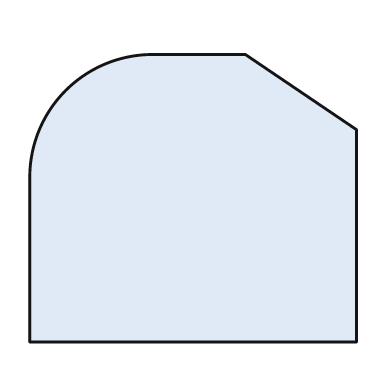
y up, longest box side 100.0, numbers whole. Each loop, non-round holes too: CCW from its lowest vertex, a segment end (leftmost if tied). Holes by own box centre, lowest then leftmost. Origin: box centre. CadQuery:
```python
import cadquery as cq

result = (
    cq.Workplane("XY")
    .moveTo(-50.0, -44.0)
    .lineTo(50.0, -44.0)
    .lineTo(50.0, 21.0)
    .lineTo(16.0, 44.0)
    .lineTo(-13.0, 44.0)
    .threePointArc((-39.0, 33.0), (-50.0, 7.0))
    .close()
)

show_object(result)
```